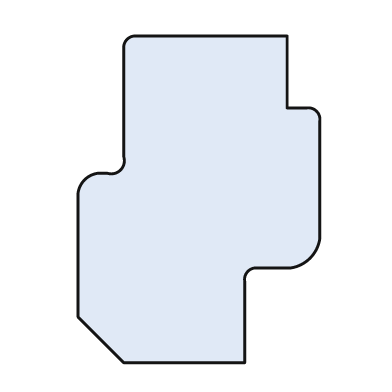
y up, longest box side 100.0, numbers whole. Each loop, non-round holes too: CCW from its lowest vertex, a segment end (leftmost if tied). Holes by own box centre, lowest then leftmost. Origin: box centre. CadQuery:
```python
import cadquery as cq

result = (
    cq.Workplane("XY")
    .moveTo(-23.0, -50.0)
    .lineTo(14.0, -50.0)
    .lineTo(14.0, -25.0)
    .threePointArc((15.0, -22.0), (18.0, -21.0))
    .lineTo(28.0, -21.0)
    .threePointArc((34.0, -18.0), (37.0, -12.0))
    .lineTo(37.0, 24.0)
    .threePointArc((36.0, 27.0), (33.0, 28.0))
    .lineTo(27.0, 28.0)
    .lineTo(27.0, 50.0)
    .lineTo(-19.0, 50.0)
    .threePointArc((-22.0, 49.0), (-23.0, 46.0))
    .lineTo(-23.0, 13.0)
    .threePointArc((-24.0, 9.0), (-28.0, 8.0))
    .lineTo(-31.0, 8.0)
    .threePointArc((-35.0, 6.0), (-37.0, 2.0))
    .lineTo(-37.0, -36.0)
    .close()
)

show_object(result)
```